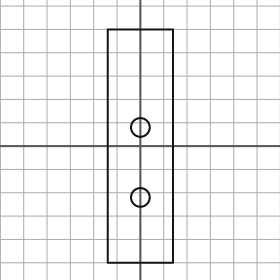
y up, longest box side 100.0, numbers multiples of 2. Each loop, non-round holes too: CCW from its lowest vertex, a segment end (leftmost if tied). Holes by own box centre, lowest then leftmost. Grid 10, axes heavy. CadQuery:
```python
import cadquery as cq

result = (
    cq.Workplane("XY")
    .moveTo(-14.0, -50.0)
    .lineTo(14.0, -50.0)
    .lineTo(14.0, 50.0)
    .lineTo(-14.0, 50.0)
    .close()
    .moveTo(0.0, -22.0)
    .circle(4.0)
    .moveTo(0.0, 8.0)
    .circle(4.0)
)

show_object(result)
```